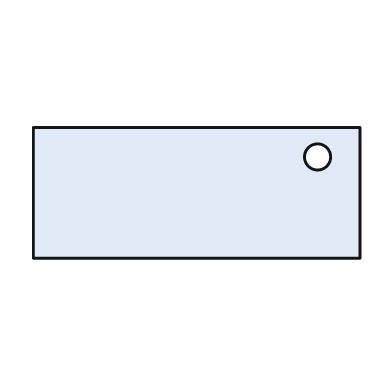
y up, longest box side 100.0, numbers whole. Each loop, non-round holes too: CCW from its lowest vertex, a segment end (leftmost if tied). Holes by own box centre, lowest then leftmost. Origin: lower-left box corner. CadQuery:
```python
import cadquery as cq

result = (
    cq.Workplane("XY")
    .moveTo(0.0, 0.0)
    .lineTo(100.0, 0.0)
    .lineTo(100.0, 40.0)
    .lineTo(0.0, 40.0)
    .close()
    .moveTo(87.0, 31.0)
    .circle(4.0)
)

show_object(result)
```